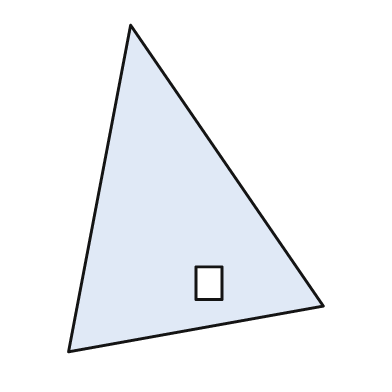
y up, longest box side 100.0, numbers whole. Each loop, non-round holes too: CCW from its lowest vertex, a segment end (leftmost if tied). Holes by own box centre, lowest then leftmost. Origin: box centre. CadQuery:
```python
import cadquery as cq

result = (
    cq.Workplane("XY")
    .moveTo(-39.0, -50.0)
    .lineTo(39.0, -36.0)
    .lineTo(-20.0, 50.0)
    .close()
    .moveTo(0.0, -34.0)
    .lineTo(8.0, -34.0)
    .lineTo(8.0, -24.0)
    .lineTo(0.0, -24.0)
    .close()
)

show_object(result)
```